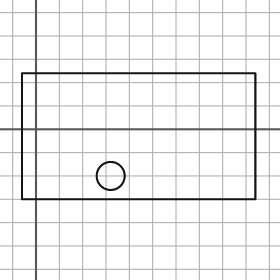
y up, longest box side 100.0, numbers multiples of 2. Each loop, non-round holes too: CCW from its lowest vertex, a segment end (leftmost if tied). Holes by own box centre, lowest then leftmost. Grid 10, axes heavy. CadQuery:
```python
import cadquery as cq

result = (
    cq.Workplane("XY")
    .moveTo(-6.0, -30.0)
    .lineTo(94.0, -30.0)
    .lineTo(94.0, 24.0)
    .lineTo(-6.0, 24.0)
    .close()
    .moveTo(32.0, -20.0)
    .circle(6.0)
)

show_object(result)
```